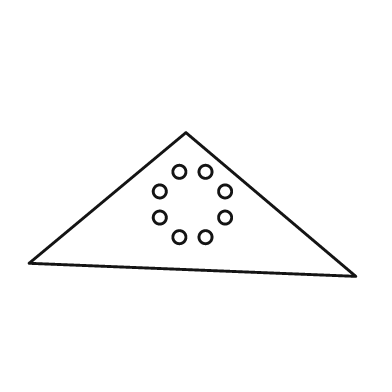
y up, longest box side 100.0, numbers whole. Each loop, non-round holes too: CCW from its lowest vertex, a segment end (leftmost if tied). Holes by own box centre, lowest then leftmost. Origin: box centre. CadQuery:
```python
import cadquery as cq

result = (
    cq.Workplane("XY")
    .moveTo(50.0, -22.0)
    .lineTo(-2.0, 22.0)
    .lineTo(-50.0, -18.0)
    .close()
    .moveTo(-4.0, -10.0)
    .circle(2.0)
    .moveTo(4.0, -10.0)
    .circle(2.0)
    .moveTo(-10.0, -4.0)
    .circle(2.0)
    .moveTo(10.0, -4.0)
    .circle(2.0)
    .moveTo(-10.0, 4.0)
    .circle(2.0)
    .moveTo(10.0, 4.0)
    .circle(2.0)
    .moveTo(-4.0, 10.0)
    .circle(2.0)
    .moveTo(4.0, 10.0)
    .circle(2.0)
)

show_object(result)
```